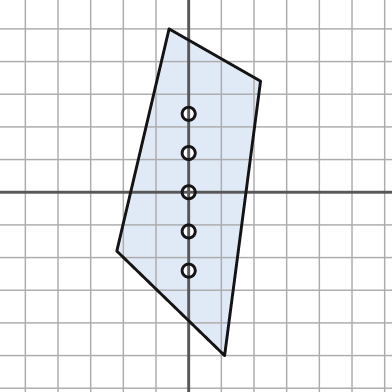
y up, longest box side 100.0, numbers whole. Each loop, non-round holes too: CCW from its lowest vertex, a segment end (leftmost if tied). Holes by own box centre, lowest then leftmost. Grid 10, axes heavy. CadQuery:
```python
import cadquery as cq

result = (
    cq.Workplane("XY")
    .moveTo(11.0, -50.0)
    .lineTo(22.0, 34.0)
    .lineTo(-6.0, 50.0)
    .lineTo(-22.0, -18.0)
    .close()
    .moveTo(0.0, -24.0)
    .circle(2.0)
    .moveTo(0.0, -12.0)
    .circle(2.0)
    .moveTo(0.0, 0.0)
    .circle(2.0)
    .moveTo(0.0, 12.0)
    .circle(2.0)
    .moveTo(0.0, 24.0)
    .circle(2.0)
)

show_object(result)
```